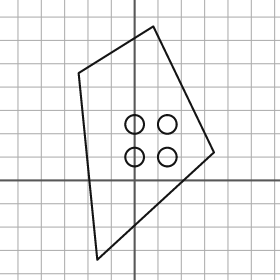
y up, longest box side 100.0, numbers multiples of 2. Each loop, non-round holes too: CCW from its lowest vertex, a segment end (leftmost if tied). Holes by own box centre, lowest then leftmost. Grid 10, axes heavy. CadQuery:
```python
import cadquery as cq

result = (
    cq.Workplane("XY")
    .moveTo(-16.0, -34.0)
    .lineTo(34.0, 12.0)
    .lineTo(8.0, 66.0)
    .lineTo(-24.0, 46.0)
    .close()
    .moveTo(0.0, 10.0)
    .circle(4.0)
    .moveTo(14.0, 10.0)
    .circle(4.0)
    .moveTo(0.0, 24.0)
    .circle(4.0)
    .moveTo(14.0, 24.0)
    .circle(4.0)
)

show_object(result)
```